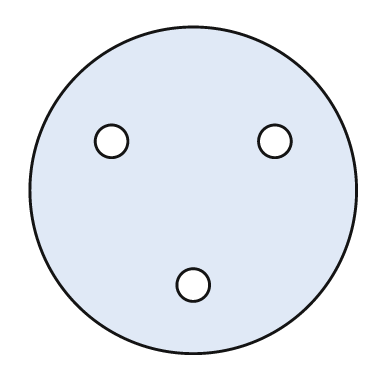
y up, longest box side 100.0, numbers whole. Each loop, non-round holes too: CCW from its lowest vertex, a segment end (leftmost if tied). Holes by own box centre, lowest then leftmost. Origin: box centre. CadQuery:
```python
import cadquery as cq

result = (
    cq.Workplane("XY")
    .moveTo(0.0, 0.0)
    .circle(50.0)
    .moveTo(0.0, -29.0)
    .circle(5.0)
    .moveTo(-25.0, 15.0)
    .circle(5.0)
    .moveTo(25.0, 15.0)
    .circle(5.0)
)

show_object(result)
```